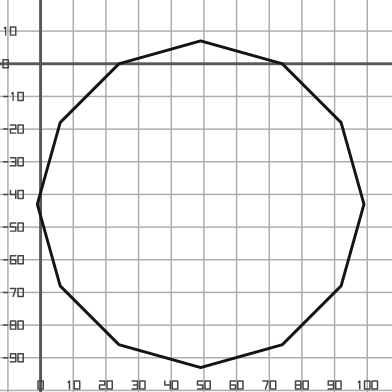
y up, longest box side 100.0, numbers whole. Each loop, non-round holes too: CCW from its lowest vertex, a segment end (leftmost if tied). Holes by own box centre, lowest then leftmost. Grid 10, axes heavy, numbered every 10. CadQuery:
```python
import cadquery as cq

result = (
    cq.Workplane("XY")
    .moveTo(49.0, -93.0)
    .lineTo(74.0, -86.0)
    .lineTo(92.0, -68.0)
    .lineTo(99.0, -43.0)
    .lineTo(92.0, -18.0)
    .lineTo(74.0, 0.0)
    .lineTo(49.0, 7.0)
    .lineTo(24.0, 0.0)
    .lineTo(6.0, -18.0)
    .lineTo(-1.0, -43.0)
    .lineTo(6.0, -68.0)
    .lineTo(24.0, -86.0)
    .close()
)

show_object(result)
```